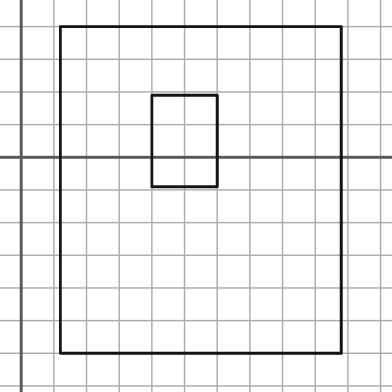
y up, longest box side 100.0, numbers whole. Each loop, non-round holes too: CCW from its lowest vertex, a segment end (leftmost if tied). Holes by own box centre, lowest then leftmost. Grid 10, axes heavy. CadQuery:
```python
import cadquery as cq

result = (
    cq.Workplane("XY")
    .moveTo(12.0, -60.0)
    .lineTo(98.0, -60.0)
    .lineTo(98.0, 40.0)
    .lineTo(12.0, 40.0)
    .close()
    .moveTo(40.0, -9.0)
    .lineTo(60.0, -9.0)
    .lineTo(60.0, 19.0)
    .lineTo(40.0, 19.0)
    .close()
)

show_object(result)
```